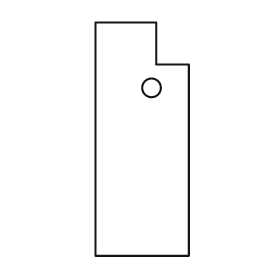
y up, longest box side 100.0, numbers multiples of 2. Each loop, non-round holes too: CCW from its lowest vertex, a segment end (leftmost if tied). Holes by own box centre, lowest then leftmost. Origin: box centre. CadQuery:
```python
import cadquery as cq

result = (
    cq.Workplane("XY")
    .moveTo(-20.0, -50.0)
    .lineTo(20.0, -50.0)
    .lineTo(20.0, 32.0)
    .lineTo(6.0, 32.0)
    .lineTo(6.0, 50.0)
    .lineTo(-20.0, 50.0)
    .close()
    .moveTo(4.0, 22.0)
    .circle(4.0)
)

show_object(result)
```